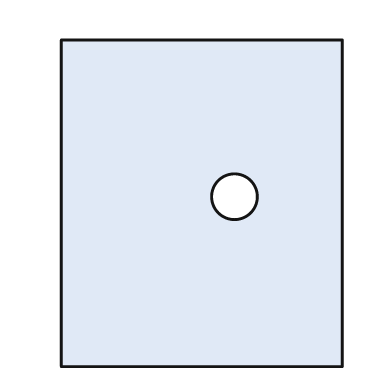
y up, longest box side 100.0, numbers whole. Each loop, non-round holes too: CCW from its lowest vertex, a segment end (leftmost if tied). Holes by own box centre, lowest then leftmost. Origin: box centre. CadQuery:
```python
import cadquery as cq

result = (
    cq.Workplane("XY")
    .moveTo(-43.0, -50.0)
    .lineTo(43.0, -50.0)
    .lineTo(43.0, 50.0)
    .lineTo(-43.0, 50.0)
    .close()
    .moveTo(10.0, 2.0)
    .circle(7.0)
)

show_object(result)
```